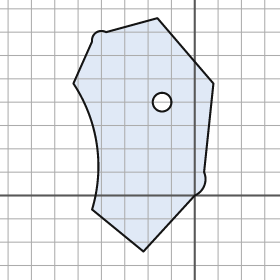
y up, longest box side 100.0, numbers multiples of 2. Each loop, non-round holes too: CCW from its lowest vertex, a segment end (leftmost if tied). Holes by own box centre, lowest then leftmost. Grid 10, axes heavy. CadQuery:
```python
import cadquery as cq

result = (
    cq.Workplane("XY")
    .moveTo(-22.0, -24.0)
    .lineTo(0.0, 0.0)
    .threePointArc((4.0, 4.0), (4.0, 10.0))
    .lineTo(8.0, 48.0)
    .lineTo(-16.0, 76.0)
    .lineTo(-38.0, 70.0)
    .threePointArc((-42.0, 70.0), (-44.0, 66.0))
    .lineTo(-52.0, 48.0)
    .threePointArc((-42.0, 22.0), (-44.0, -6.0))
    .close()
    .moveTo(-14.0, 40.0)
    .circle(4.0)
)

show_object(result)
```